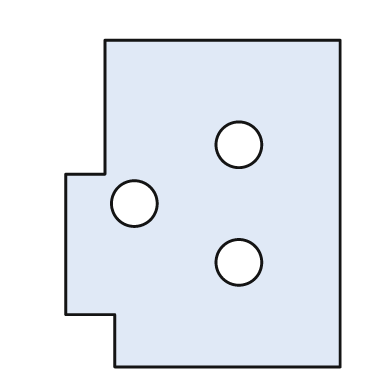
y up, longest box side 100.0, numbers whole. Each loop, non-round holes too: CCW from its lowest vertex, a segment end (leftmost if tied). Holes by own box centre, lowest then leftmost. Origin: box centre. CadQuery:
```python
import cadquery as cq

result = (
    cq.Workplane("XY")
    .moveTo(-27.0, -50.0)
    .lineTo(42.0, -50.0)
    .lineTo(42.0, 50.0)
    .lineTo(-30.0, 50.0)
    .lineTo(-30.0, 9.0)
    .lineTo(-42.0, 9.0)
    .lineTo(-42.0, -34.0)
    .lineTo(-27.0, -34.0)
    .close()
    .moveTo(11.0, -18.0)
    .circle(7.0)
    .moveTo(-21.0, 0.0)
    .circle(7.0)
    .moveTo(11.0, 18.0)
    .circle(7.0)
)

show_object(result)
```